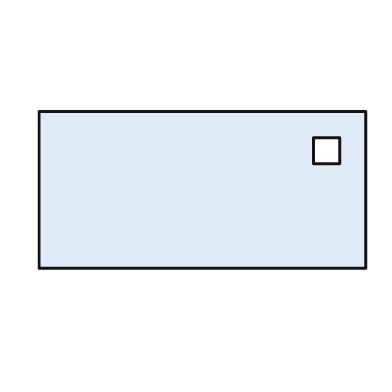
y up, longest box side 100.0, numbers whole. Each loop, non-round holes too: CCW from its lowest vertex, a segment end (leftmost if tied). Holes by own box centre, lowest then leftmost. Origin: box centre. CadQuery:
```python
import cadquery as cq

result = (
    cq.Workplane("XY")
    .moveTo(-50.0, -24.0)
    .lineTo(50.0, -24.0)
    .lineTo(50.0, 24.0)
    .lineTo(-50.0, 24.0)
    .close()
    .moveTo(34.0, 8.0)
    .lineTo(42.0, 8.0)
    .lineTo(42.0, 16.0)
    .lineTo(34.0, 16.0)
    .close()
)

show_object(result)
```